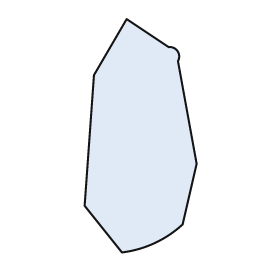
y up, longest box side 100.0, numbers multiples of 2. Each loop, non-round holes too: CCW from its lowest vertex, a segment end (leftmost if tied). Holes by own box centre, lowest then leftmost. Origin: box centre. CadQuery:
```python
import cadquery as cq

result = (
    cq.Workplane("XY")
    .moveTo(-8.0, -50.0)
    .threePointArc((6.0, -46.0), (18.0, -38.0))
    .lineTo(24.0, -12.0)
    .lineTo(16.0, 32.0)
    .threePointArc((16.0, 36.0), (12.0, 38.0))
    .lineTo(-6.0, 50.0)
    .lineTo(-20.0, 26.0)
    .lineTo(-24.0, -30.0)
    .close()
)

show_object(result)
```